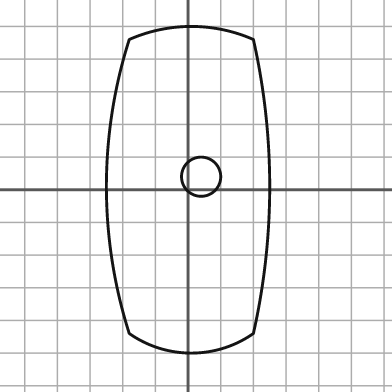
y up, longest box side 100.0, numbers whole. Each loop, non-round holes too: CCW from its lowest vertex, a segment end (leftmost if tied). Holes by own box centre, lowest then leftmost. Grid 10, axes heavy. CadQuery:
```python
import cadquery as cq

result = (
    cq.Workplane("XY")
    .moveTo(-18.0, -44.0)
    .threePointArc((1.0, -50.0), (20.0, -44.0))
    .threePointArc((25.0, 1.0), (20.0, 46.0))
    .threePointArc((1.0, 50.0), (-18.0, 46.0))
    .threePointArc((-25.0, 1.0), (-18.0, -44.0))
    .close()
    .moveTo(4.0, 4.0)
    .circle(6.0)
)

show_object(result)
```